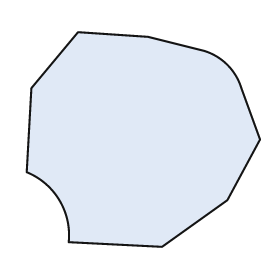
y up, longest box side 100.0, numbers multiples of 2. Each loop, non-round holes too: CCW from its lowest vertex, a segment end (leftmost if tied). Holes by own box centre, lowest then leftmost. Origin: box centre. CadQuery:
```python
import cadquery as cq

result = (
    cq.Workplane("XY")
    .moveTo(8.0, -46.0)
    .lineTo(36.0, -26.0)
    .lineTo(50.0, 0.0)
    .lineTo(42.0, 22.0)
    .threePointArc((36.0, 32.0), (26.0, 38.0))
    .lineTo(2.0, 44.0)
    .lineTo(-28.0, 46.0)
    .lineTo(-48.0, 22.0)
    .lineTo(-50.0, -14.0)
    .threePointArc((-36.0, -26.0), (-32.0, -44.0))
    .close()
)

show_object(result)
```